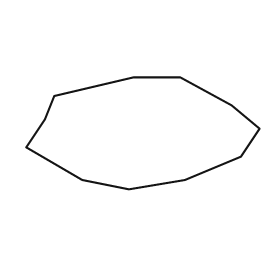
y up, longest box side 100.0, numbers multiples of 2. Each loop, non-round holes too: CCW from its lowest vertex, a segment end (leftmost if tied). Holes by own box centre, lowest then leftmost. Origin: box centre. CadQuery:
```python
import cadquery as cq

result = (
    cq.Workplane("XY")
    .moveTo(-6.0, -24.0)
    .lineTo(18.0, -20.0)
    .lineTo(42.0, -10.0)
    .lineTo(50.0, 2.0)
    .lineTo(38.0, 12.0)
    .lineTo(16.0, 24.0)
    .lineTo(-4.0, 24.0)
    .lineTo(-38.0, 16.0)
    .lineTo(-42.0, 6.0)
    .lineTo(-50.0, -6.0)
    .lineTo(-26.0, -20.0)
    .close()
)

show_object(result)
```